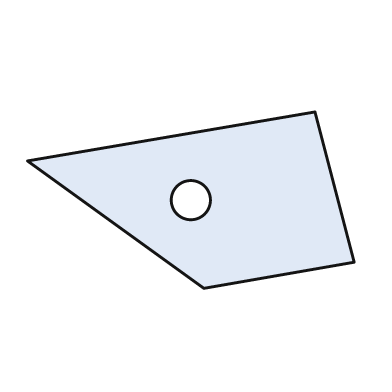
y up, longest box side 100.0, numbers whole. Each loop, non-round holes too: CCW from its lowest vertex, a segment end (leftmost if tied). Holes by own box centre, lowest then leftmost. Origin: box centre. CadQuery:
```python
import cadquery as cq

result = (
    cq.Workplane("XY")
    .moveTo(4.0, -27.0)
    .lineTo(50.0, -19.0)
    .lineTo(38.0, 27.0)
    .lineTo(-50.0, 12.0)
    .close()
    .moveTo(0.0, 0.0)
    .circle(6.0)
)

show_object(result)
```